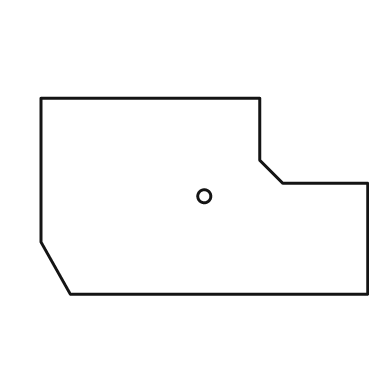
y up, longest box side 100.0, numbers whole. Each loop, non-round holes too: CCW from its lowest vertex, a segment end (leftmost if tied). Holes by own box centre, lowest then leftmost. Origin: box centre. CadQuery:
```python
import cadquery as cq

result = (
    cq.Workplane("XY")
    .moveTo(-41.0, -30.0)
    .lineTo(50.0, -30.0)
    .lineTo(50.0, 4.0)
    .lineTo(24.0, 4.0)
    .lineTo(17.0, 11.0)
    .lineTo(17.0, 30.0)
    .lineTo(-50.0, 30.0)
    .lineTo(-50.0, -14.0)
    .close()
    .moveTo(0.0, 0.0)
    .circle(2.0)
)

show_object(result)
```